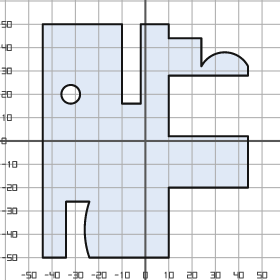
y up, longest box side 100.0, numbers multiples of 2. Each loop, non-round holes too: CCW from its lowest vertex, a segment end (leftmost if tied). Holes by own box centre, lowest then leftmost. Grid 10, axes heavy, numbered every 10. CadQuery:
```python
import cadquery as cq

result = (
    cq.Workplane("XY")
    .moveTo(-44.0, -50.0)
    .lineTo(-34.0, -50.0)
    .lineTo(-34.0, -26.0)
    .lineTo(-24.0, -26.0)
    .threePointArc((-26.0, -38.0), (-24.0, -50.0))
    .lineTo(10.0, -50.0)
    .lineTo(10.0, -20.0)
    .lineTo(44.0, -20.0)
    .lineTo(44.0, 2.0)
    .lineTo(10.0, 2.0)
    .lineTo(10.0, 28.0)
    .lineTo(44.0, 28.0)
    .lineTo(44.0, 32.0)
    .threePointArc((34.0, 38.0), (24.0, 32.0))
    .lineTo(24.0, 44.0)
    .lineTo(10.0, 44.0)
    .lineTo(10.0, 50.0)
    .lineTo(-2.0, 50.0)
    .lineTo(-2.0, 16.0)
    .lineTo(-10.0, 16.0)
    .lineTo(-10.0, 50.0)
    .lineTo(-44.0, 50.0)
    .close()
    .moveTo(-32.0, 20.0)
    .circle(4.0)
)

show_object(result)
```